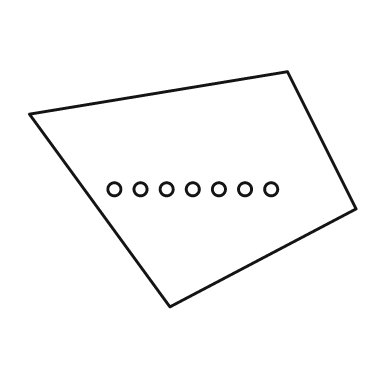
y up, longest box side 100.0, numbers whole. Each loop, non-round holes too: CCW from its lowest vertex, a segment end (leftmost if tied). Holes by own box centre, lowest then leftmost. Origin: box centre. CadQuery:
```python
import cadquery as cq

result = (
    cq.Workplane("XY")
    .moveTo(-7.0, -36.0)
    .lineTo(50.0, -6.0)
    .lineTo(29.0, 36.0)
    .lineTo(-50.0, 23.0)
    .close()
    .moveTo(-24.0, 0.0)
    .circle(2.0)
    .moveTo(-16.0, 0.0)
    .circle(2.0)
    .moveTo(-8.0, 0.0)
    .circle(2.0)
    .moveTo(0.0, 0.0)
    .circle(2.0)
    .moveTo(8.0, 0.0)
    .circle(2.0)
    .moveTo(16.0, 0.0)
    .circle(2.0)
    .moveTo(24.0, 0.0)
    .circle(2.0)
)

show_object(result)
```